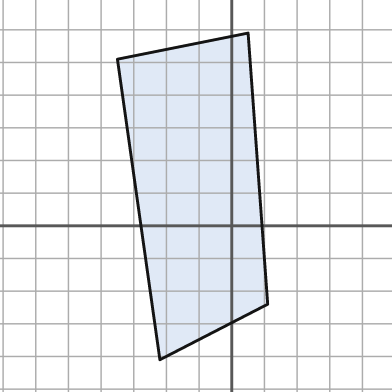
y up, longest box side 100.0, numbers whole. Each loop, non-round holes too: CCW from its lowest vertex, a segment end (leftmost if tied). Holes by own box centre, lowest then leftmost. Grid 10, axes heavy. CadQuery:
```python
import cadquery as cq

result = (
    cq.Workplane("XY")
    .moveTo(-22.0, -41.0)
    .lineTo(11.0, -24.0)
    .lineTo(5.0, 59.0)
    .lineTo(-35.0, 51.0)
    .close()
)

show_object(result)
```